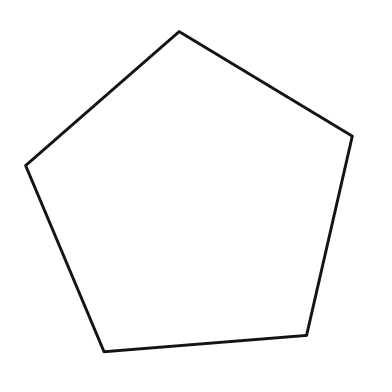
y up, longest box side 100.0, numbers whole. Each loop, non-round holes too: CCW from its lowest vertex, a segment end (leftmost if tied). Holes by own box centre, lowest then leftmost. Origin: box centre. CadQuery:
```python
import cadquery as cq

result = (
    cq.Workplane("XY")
    .moveTo(-26.0, -49.0)
    .lineTo(36.0, -44.0)
    .lineTo(50.0, 17.0)
    .lineTo(-3.0, 49.0)
    .lineTo(-50.0, 8.0)
    .close()
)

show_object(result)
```